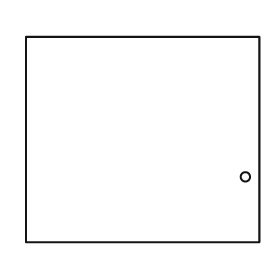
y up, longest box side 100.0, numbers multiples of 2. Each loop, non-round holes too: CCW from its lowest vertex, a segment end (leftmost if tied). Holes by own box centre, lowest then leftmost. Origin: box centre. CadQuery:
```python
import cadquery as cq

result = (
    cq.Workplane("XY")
    .moveTo(-50.0, -44.0)
    .lineTo(50.0, -44.0)
    .lineTo(50.0, 44.0)
    .lineTo(-50.0, 44.0)
    .close()
    .moveTo(44.0, -16.0)
    .circle(2.0)
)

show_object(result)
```